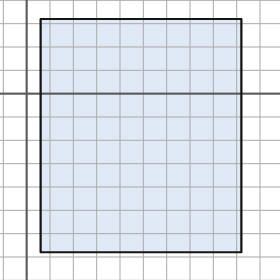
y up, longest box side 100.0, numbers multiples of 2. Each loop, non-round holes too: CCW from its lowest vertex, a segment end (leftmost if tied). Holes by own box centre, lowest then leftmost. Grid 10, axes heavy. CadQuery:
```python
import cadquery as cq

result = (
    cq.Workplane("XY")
    .moveTo(6.0, -68.0)
    .lineTo(92.0, -68.0)
    .lineTo(92.0, 32.0)
    .lineTo(6.0, 32.0)
    .close()
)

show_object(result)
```